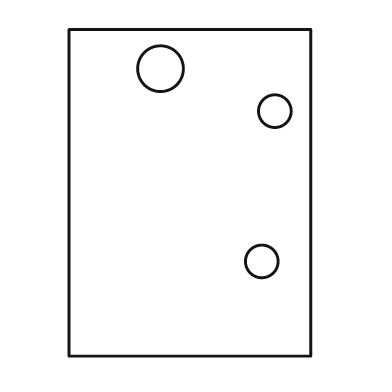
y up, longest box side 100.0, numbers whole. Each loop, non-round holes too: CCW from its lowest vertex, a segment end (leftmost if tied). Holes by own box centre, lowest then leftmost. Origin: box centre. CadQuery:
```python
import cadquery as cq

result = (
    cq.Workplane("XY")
    .moveTo(-37.0, -50.0)
    .lineTo(37.0, -50.0)
    .lineTo(37.0, 50.0)
    .lineTo(-37.0, 50.0)
    .close()
    .moveTo(22.0, -21.0)
    .circle(5.0)
    .moveTo(26.0, 25.0)
    .circle(5.0)
    .moveTo(-9.0, 38.0)
    .circle(7.0)
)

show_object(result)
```